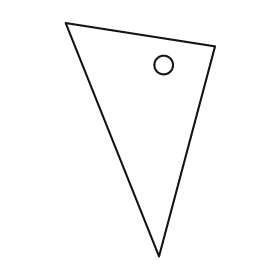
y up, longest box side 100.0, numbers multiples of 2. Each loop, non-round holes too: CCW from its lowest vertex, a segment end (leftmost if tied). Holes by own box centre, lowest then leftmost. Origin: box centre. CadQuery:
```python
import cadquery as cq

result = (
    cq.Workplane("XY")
    .moveTo(8.0, -50.0)
    .lineTo(32.0, 40.0)
    .lineTo(-32.0, 50.0)
    .close()
    .moveTo(10.0, 32.0)
    .circle(4.0)
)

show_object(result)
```